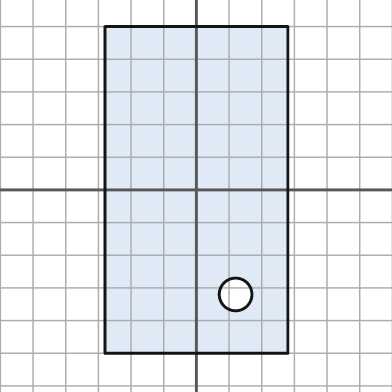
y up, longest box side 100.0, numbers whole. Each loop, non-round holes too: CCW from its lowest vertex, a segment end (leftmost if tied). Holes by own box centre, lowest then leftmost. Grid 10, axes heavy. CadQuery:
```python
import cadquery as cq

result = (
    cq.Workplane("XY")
    .moveTo(-28.0, -50.0)
    .lineTo(28.0, -50.0)
    .lineTo(28.0, 50.0)
    .lineTo(-28.0, 50.0)
    .close()
    .moveTo(12.0, -32.0)
    .circle(5.0)
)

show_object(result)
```